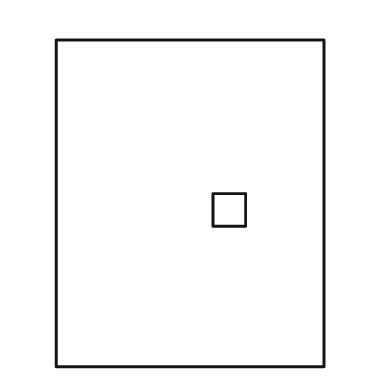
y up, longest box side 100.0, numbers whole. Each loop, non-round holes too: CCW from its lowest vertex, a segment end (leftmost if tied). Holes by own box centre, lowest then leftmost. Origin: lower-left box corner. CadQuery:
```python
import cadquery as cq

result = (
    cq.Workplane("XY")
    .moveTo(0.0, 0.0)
    .lineTo(82.0, 0.0)
    .lineTo(82.0, 100.0)
    .lineTo(0.0, 100.0)
    .close()
    .moveTo(48.0, 43.0)
    .lineTo(58.0, 43.0)
    .lineTo(58.0, 53.0)
    .lineTo(48.0, 53.0)
    .close()
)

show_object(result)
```